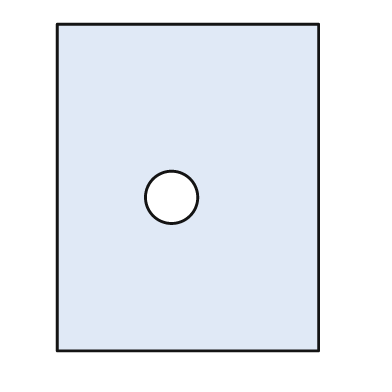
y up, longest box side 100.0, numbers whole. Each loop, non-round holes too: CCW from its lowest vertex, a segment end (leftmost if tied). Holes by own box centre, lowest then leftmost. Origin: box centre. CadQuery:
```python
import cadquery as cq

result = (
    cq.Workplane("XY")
    .moveTo(-40.0, -50.0)
    .lineTo(40.0, -50.0)
    .lineTo(40.0, 50.0)
    .lineTo(-40.0, 50.0)
    .close()
    .moveTo(-5.0, -3.0)
    .circle(8.0)
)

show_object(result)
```